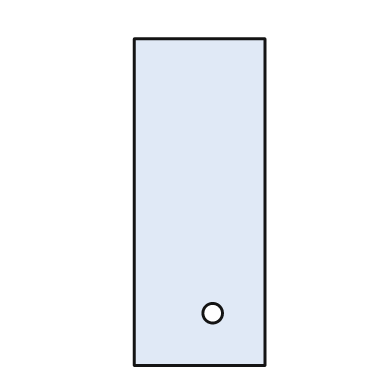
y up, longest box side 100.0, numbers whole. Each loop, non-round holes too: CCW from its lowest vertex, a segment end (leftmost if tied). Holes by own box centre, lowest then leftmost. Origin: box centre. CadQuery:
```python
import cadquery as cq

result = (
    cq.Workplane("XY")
    .moveTo(-20.0, -50.0)
    .lineTo(20.0, -50.0)
    .lineTo(20.0, 50.0)
    .lineTo(-20.0, 50.0)
    .close()
    .moveTo(4.0, -34.0)
    .circle(3.0)
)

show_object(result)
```